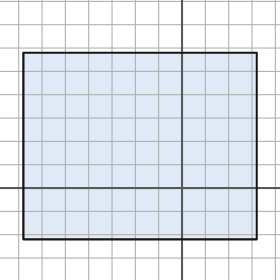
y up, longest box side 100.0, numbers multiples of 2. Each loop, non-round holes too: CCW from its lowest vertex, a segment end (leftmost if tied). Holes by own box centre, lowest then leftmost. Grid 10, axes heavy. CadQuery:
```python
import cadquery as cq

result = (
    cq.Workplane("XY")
    .moveTo(-68.0, -22.0)
    .lineTo(32.0, -22.0)
    .lineTo(32.0, 58.0)
    .lineTo(-68.0, 58.0)
    .close()
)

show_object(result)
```